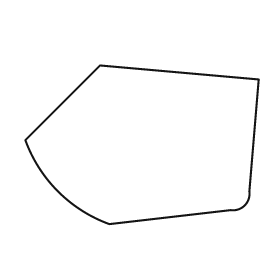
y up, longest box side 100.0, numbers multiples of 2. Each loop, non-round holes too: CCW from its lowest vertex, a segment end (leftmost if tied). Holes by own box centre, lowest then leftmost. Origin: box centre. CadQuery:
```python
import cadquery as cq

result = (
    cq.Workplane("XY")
    .moveTo(-14.0, -34.0)
    .lineTo(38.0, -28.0)
    .threePointArc((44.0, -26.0), (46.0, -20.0))
    .lineTo(50.0, 28.0)
    .lineTo(-18.0, 34.0)
    .lineTo(-50.0, 2.0)
    .threePointArc((-36.0, -20.0), (-14.0, -34.0))
    .close()
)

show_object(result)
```